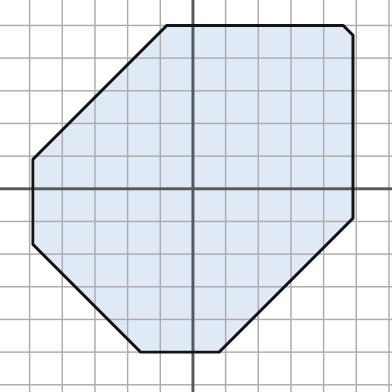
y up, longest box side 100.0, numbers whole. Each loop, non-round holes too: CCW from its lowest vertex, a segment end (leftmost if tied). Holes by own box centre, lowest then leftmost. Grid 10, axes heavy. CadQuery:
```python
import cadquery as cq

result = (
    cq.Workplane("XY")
    .moveTo(-16.0, -50.0)
    .lineTo(8.0, -50.0)
    .lineTo(49.0, -9.0)
    .lineTo(49.0, 47.0)
    .lineTo(46.0, 50.0)
    .lineTo(-8.0, 50.0)
    .lineTo(-49.0, 9.0)
    .lineTo(-49.0, -17.0)
    .close()
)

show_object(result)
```